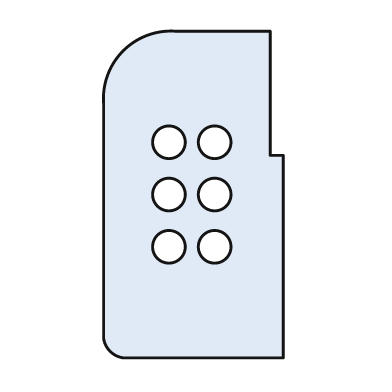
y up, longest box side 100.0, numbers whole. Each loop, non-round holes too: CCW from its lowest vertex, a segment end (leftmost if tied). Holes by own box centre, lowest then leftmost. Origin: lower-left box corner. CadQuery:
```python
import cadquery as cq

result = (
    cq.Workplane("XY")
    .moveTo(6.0, 0.0)
    .lineTo(55.0, 0.0)
    .lineTo(55.0, 62.0)
    .lineTo(51.0, 62.0)
    .lineTo(51.0, 100.0)
    .lineTo(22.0, 100.0)
    .threePointArc((6.0, 94.0), (0.0, 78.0))
    .lineTo(0.0, 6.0)
    .threePointArc((2.0, 2.0), (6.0, 0.0))
    .close()
    .moveTo(20.0, 34.0)
    .circle(5.0)
    .moveTo(34.0, 34.0)
    .circle(5.0)
    .moveTo(20.0, 50.0)
    .circle(5.0)
    .moveTo(34.0, 50.0)
    .circle(5.0)
    .moveTo(20.0, 66.0)
    .circle(5.0)
    .moveTo(34.0, 66.0)
    .circle(5.0)
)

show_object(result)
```